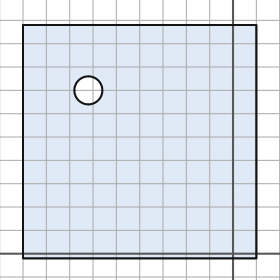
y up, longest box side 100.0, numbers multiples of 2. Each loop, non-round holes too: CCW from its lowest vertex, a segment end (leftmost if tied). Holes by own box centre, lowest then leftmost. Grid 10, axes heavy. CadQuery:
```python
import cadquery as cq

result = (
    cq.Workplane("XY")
    .moveTo(-90.0, -2.0)
    .lineTo(10.0, -2.0)
    .lineTo(10.0, 98.0)
    .lineTo(-90.0, 98.0)
    .close()
    .moveTo(-62.0, 70.0)
    .circle(6.0)
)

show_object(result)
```